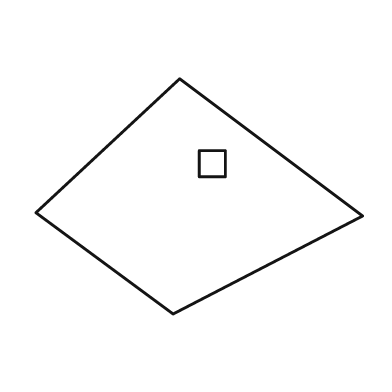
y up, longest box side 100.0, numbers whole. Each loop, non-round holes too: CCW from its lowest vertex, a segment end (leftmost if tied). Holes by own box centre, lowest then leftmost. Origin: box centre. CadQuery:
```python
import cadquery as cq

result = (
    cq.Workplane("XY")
    .moveTo(-8.0, -36.0)
    .lineTo(50.0, -6.0)
    .lineTo(-6.0, 36.0)
    .lineTo(-50.0, -5.0)
    .close()
    .moveTo(0.0, 6.0)
    .lineTo(8.0, 6.0)
    .lineTo(8.0, 14.0)
    .lineTo(0.0, 14.0)
    .close()
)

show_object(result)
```